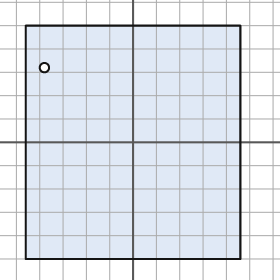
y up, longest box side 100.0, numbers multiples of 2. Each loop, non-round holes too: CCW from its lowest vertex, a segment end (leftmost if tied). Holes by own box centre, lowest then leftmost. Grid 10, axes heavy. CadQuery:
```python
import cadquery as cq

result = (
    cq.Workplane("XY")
    .moveTo(-46.0, -50.0)
    .lineTo(46.0, -50.0)
    .lineTo(46.0, 50.0)
    .lineTo(-46.0, 50.0)
    .close()
    .moveTo(-38.0, 32.0)
    .circle(2.0)
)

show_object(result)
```